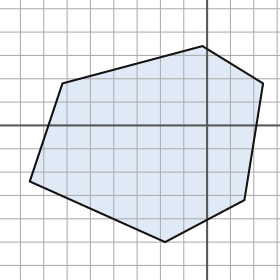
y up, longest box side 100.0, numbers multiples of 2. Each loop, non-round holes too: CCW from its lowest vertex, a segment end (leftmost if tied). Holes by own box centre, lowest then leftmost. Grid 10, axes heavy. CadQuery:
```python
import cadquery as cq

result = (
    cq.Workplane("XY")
    .moveTo(-18.0, -50.0)
    .lineTo(16.0, -32.0)
    .lineTo(24.0, 18.0)
    .lineTo(-2.0, 34.0)
    .lineTo(-62.0, 18.0)
    .lineTo(-76.0, -24.0)
    .close()
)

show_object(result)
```